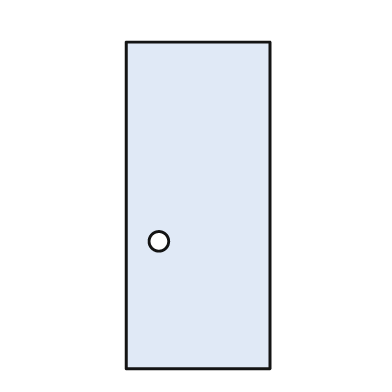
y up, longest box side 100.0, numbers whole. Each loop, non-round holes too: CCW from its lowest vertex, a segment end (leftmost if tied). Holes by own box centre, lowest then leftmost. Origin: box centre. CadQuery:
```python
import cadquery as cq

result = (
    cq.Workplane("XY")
    .moveTo(-22.0, -50.0)
    .lineTo(22.0, -50.0)
    .lineTo(22.0, 50.0)
    .lineTo(-22.0, 50.0)
    .close()
    .moveTo(-12.0, -11.0)
    .circle(3.0)
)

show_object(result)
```